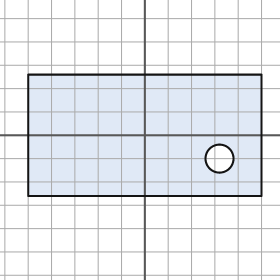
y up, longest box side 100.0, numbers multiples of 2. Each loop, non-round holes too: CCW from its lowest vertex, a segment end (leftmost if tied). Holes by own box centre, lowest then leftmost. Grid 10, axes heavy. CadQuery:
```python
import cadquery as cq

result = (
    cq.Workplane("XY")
    .moveTo(-50.0, -26.0)
    .lineTo(50.0, -26.0)
    .lineTo(50.0, 26.0)
    .lineTo(-50.0, 26.0)
    .close()
    .moveTo(32.0, -10.0)
    .circle(6.0)
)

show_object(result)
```